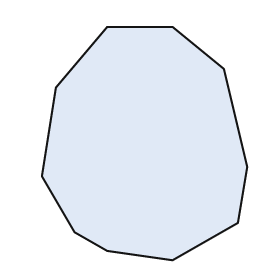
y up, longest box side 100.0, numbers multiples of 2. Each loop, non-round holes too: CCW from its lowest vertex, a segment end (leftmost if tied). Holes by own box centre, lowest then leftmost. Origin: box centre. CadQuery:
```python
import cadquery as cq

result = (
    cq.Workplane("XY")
    .moveTo(12.0, -50.0)
    .lineTo(40.0, -34.0)
    .lineTo(44.0, -10.0)
    .lineTo(34.0, 32.0)
    .lineTo(12.0, 50.0)
    .lineTo(-16.0, 50.0)
    .lineTo(-38.0, 24.0)
    .lineTo(-44.0, -14.0)
    .lineTo(-30.0, -38.0)
    .lineTo(-16.0, -46.0)
    .close()
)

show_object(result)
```